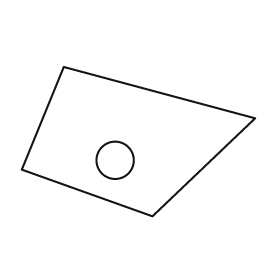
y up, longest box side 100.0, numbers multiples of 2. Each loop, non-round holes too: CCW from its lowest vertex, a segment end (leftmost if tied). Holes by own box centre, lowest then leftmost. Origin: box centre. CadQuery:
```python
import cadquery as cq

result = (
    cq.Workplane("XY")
    .moveTo(6.0, -32.0)
    .lineTo(50.0, 10.0)
    .lineTo(-32.0, 32.0)
    .lineTo(-50.0, -12.0)
    .close()
    .moveTo(-10.0, -8.0)
    .circle(8.0)
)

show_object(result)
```